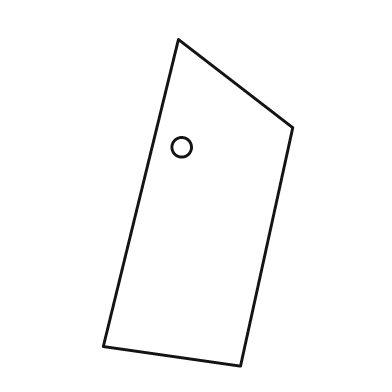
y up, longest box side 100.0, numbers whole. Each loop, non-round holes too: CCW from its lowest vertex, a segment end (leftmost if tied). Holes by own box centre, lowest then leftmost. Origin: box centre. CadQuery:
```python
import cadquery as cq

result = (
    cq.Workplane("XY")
    .moveTo(13.0, -50.0)
    .lineTo(29.0, 23.0)
    .lineTo(-6.0, 50.0)
    .lineTo(-29.0, -44.0)
    .close()
    .moveTo(-5.0, 17.0)
    .circle(3.0)
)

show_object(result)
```